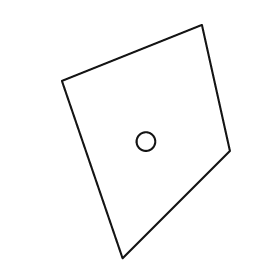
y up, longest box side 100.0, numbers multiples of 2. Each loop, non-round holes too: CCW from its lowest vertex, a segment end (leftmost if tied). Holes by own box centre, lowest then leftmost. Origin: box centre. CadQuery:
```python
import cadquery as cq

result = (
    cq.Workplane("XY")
    .moveTo(-10.0, -50.0)
    .lineTo(36.0, -4.0)
    .lineTo(24.0, 50.0)
    .lineTo(-36.0, 26.0)
    .close()
    .moveTo(0.0, 0.0)
    .circle(4.0)
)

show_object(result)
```